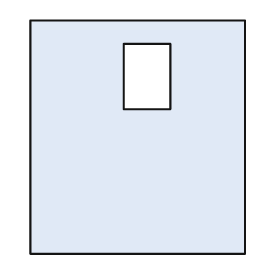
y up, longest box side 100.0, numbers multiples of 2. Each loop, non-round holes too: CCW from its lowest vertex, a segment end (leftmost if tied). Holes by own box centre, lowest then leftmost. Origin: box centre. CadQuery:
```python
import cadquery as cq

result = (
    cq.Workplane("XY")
    .moveTo(-46.0, -50.0)
    .lineTo(46.0, -50.0)
    .lineTo(46.0, 50.0)
    .lineTo(-46.0, 50.0)
    .close()
    .moveTo(-6.0, 12.0)
    .lineTo(14.0, 12.0)
    .lineTo(14.0, 40.0)
    .lineTo(-6.0, 40.0)
    .close()
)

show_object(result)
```